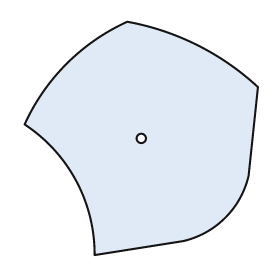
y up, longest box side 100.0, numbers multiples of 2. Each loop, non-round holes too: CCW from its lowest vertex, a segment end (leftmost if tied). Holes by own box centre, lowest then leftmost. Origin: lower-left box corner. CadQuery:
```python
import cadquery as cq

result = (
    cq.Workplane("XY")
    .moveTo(30.0, 0.0)
    .lineTo(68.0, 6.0)
    .threePointArc((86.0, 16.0), (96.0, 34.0))
    .lineTo(100.0, 72.0)
    .threePointArc((74.0, 90.0), (44.0, 100.0))
    .threePointArc((18.0, 82.0), (0.0, 56.0))
    .threePointArc((22.0, 32.0), (30.0, 0.0))
    .close()
    .moveTo(50.0, 50.0)
    .circle(2.0)
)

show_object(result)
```